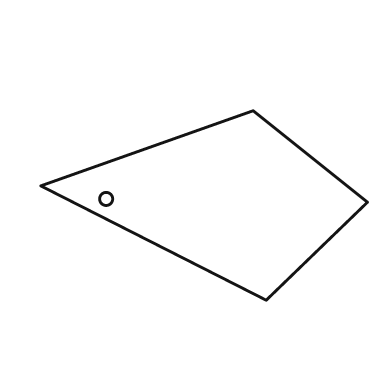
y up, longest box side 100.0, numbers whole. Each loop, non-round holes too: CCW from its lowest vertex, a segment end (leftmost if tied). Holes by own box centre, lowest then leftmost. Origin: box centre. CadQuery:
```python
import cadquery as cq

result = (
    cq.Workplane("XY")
    .moveTo(19.0, -29.0)
    .lineTo(50.0, 1.0)
    .lineTo(15.0, 29.0)
    .lineTo(-50.0, 6.0)
    .close()
    .moveTo(-30.0, 2.0)
    .circle(2.0)
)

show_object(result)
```